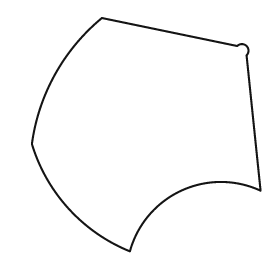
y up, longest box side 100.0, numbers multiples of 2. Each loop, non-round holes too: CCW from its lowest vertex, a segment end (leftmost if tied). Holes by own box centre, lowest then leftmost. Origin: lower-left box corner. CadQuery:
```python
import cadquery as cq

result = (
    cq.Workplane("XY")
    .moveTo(42.0, 0.0)
    .threePointArc((64.0, 26.0), (98.0, 26.0))
    .lineTo(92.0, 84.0)
    .threePointArc((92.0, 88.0), (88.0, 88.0))
    .lineTo(30.0, 100.0)
    .threePointArc((10.0, 76.0), (0.0, 46.0))
    .threePointArc((16.0, 18.0), (42.0, 0.0))
    .close()
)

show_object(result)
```